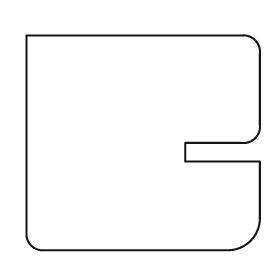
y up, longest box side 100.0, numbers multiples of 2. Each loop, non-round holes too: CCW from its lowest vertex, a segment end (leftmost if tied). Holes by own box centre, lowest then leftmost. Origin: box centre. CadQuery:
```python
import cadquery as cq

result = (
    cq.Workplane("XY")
    .moveTo(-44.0, -46.0)
    .lineTo(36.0, -46.0)
    .threePointArc((46.0, -42.0), (50.0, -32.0))
    .lineTo(50.0, -8.0)
    .lineTo(18.0, -8.0)
    .lineTo(18.0, 0.0)
    .lineTo(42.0, 0.0)
    .threePointArc((48.0, 2.0), (50.0, 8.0))
    .lineTo(50.0, 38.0)
    .threePointArc((48.0, 44.0), (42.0, 46.0))
    .lineTo(-50.0, 46.0)
    .lineTo(-50.0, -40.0)
    .threePointArc((-48.0, -44.0), (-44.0, -46.0))
    .close()
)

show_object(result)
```